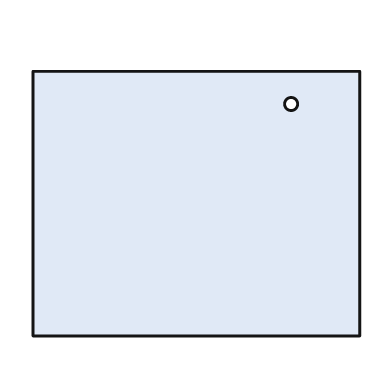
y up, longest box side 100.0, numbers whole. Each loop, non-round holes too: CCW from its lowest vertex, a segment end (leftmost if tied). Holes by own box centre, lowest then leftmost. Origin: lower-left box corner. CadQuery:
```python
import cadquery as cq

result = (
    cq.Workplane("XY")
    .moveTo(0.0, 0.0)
    .lineTo(100.0, 0.0)
    .lineTo(100.0, 81.0)
    .lineTo(0.0, 81.0)
    .close()
    .moveTo(79.0, 71.0)
    .circle(2.0)
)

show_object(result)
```